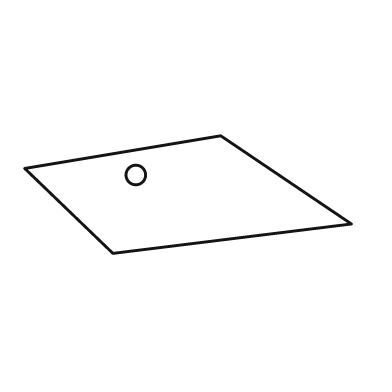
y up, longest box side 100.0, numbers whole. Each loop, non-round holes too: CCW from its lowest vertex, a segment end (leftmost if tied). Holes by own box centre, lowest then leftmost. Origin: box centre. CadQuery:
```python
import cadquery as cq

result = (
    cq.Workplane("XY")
    .moveTo(-23.0, -18.0)
    .lineTo(50.0, -9.0)
    .lineTo(10.0, 18.0)
    .lineTo(-50.0, 8.0)
    .close()
    .moveTo(-16.0, 6.0)
    .circle(3.0)
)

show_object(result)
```